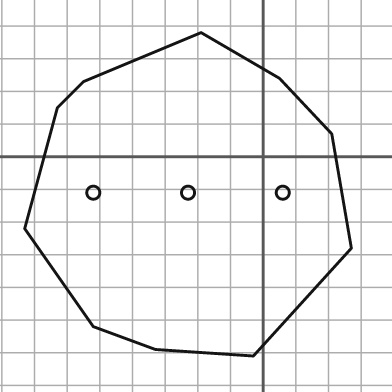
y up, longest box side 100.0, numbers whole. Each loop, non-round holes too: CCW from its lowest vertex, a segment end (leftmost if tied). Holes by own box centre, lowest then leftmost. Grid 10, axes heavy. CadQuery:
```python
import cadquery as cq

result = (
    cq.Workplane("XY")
    .moveTo(-3.0, -61.0)
    .lineTo(27.0, -28.0)
    .lineTo(21.0, 7.0)
    .lineTo(5.0, 24.0)
    .lineTo(-19.0, 38.0)
    .lineTo(-55.0, 23.0)
    .lineTo(-63.0, 15.0)
    .lineTo(-73.0, -22.0)
    .lineTo(-52.0, -52.0)
    .lineTo(-33.0, -59.0)
    .close()
    .moveTo(-52.0, -11.0)
    .circle(2.0)
    .moveTo(-23.0, -11.0)
    .circle(2.0)
    .moveTo(6.0, -11.0)
    .circle(2.0)
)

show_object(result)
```